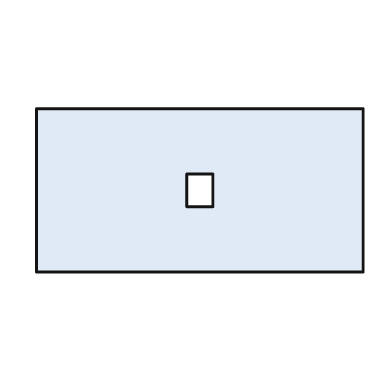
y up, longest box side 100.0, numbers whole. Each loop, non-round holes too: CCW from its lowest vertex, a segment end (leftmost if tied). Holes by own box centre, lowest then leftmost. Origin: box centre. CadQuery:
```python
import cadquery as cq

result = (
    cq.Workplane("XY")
    .moveTo(-50.0, -25.0)
    .lineTo(50.0, -25.0)
    .lineTo(50.0, 25.0)
    .lineTo(-50.0, 25.0)
    .close()
    .moveTo(-4.0, -5.0)
    .lineTo(4.0, -5.0)
    .lineTo(4.0, 5.0)
    .lineTo(-4.0, 5.0)
    .close()
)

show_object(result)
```